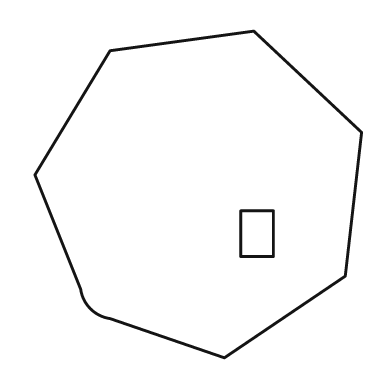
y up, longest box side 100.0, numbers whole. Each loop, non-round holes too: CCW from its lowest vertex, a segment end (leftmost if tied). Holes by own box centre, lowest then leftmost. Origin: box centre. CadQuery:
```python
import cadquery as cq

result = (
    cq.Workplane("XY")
    .moveTo(8.0, -50.0)
    .lineTo(45.0, -25.0)
    .lineTo(50.0, 19.0)
    .lineTo(17.0, 50.0)
    .lineTo(-27.0, 44.0)
    .lineTo(-50.0, 6.0)
    .lineTo(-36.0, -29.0)
    .threePointArc((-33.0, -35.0), (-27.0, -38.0))
    .close()
    .moveTo(13.0, -19.0)
    .lineTo(23.0, -19.0)
    .lineTo(23.0, -5.0)
    .lineTo(13.0, -5.0)
    .close()
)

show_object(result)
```